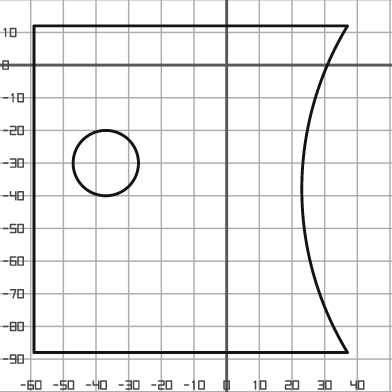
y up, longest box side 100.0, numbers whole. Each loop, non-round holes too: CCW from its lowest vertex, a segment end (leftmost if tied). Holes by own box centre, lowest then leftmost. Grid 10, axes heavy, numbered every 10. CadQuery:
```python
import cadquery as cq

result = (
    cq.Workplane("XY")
    .moveTo(-59.0, -88.0)
    .lineTo(37.0, -88.0)
    .threePointArc((23.0, -38.0), (37.0, 12.0))
    .lineTo(-59.0, 12.0)
    .close()
    .moveTo(-37.0, -30.0)
    .circle(10.0)
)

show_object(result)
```